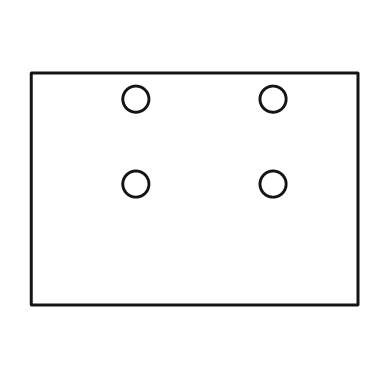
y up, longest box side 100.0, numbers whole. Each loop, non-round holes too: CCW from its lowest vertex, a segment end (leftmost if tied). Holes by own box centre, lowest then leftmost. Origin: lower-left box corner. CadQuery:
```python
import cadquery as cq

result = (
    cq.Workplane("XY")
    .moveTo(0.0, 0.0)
    .lineTo(100.0, 0.0)
    .lineTo(100.0, 71.0)
    .lineTo(0.0, 71.0)
    .close()
    .moveTo(32.0, 37.0)
    .circle(4.0)
    .moveTo(74.0, 37.0)
    .circle(4.0)
    .moveTo(32.0, 63.0)
    .circle(4.0)
    .moveTo(74.0, 63.0)
    .circle(4.0)
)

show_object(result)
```